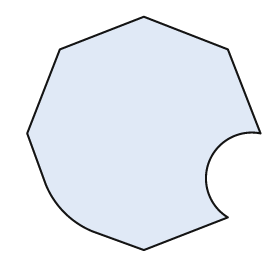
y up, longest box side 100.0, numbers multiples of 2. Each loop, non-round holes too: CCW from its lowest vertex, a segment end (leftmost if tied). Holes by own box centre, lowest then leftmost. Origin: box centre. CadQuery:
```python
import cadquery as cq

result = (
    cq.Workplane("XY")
    .moveTo(0.0, -50.0)
    .lineTo(36.0, -36.0)
    .threePointArc((28.0, -12.0), (50.0, 0.0))
    .lineTo(36.0, 36.0)
    .lineTo(0.0, 50.0)
    .lineTo(-36.0, 36.0)
    .lineTo(-50.0, 0.0)
    .lineTo(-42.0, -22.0)
    .threePointArc((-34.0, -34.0), (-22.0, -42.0))
    .close()
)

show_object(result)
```